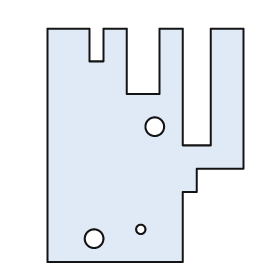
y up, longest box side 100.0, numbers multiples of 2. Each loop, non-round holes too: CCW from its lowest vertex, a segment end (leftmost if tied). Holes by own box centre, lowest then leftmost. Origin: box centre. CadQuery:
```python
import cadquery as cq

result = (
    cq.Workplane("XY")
    .moveTo(-42.0, -50.0)
    .lineTo(16.0, -50.0)
    .lineTo(16.0, -20.0)
    .lineTo(22.0, -20.0)
    .lineTo(22.0, -10.0)
    .lineTo(42.0, -10.0)
    .lineTo(42.0, 50.0)
    .lineTo(28.0, 50.0)
    .lineTo(28.0, 0.0)
    .lineTo(16.0, 0.0)
    .lineTo(16.0, 50.0)
    .lineTo(6.0, 50.0)
    .lineTo(6.0, 22.0)
    .lineTo(-8.0, 22.0)
    .lineTo(-8.0, 50.0)
    .lineTo(-18.0, 50.0)
    .lineTo(-18.0, 36.0)
    .lineTo(-24.0, 36.0)
    .lineTo(-24.0, 50.0)
    .lineTo(-42.0, 50.0)
    .close()
    .moveTo(-22.0, -40.0)
    .circle(4.0)
    .moveTo(-2.0, -36.0)
    .circle(2.0)
    .moveTo(4.0, 8.0)
    .circle(4.0)
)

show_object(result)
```